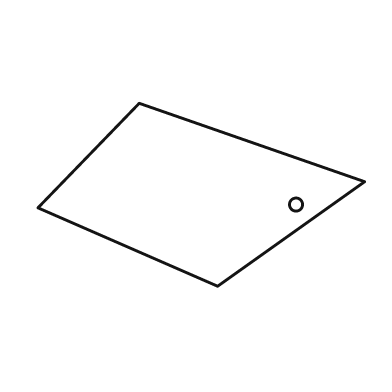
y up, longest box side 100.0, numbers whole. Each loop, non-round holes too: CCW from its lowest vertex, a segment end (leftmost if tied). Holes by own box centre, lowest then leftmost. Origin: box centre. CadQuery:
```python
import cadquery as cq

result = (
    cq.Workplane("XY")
    .moveTo(5.0, -28.0)
    .lineTo(50.0, 4.0)
    .lineTo(-19.0, 28.0)
    .lineTo(-50.0, -4.0)
    .close()
    .moveTo(29.0, -3.0)
    .circle(2.0)
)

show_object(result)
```